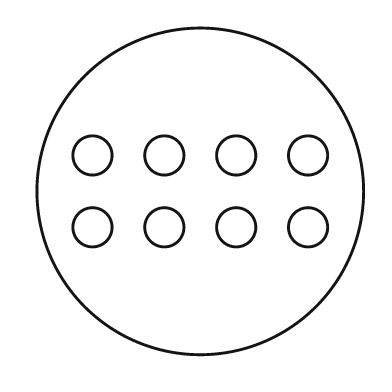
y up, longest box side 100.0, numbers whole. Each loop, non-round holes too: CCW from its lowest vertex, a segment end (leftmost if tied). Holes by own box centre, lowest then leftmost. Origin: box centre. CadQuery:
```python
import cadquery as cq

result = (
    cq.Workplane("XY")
    .moveTo(0.0, 0.0)
    .circle(50.0)
    .moveTo(-33.0, -11.0)
    .circle(6.0)
    .moveTo(-11.0, -11.0)
    .circle(6.0)
    .moveTo(11.0, -11.0)
    .circle(6.0)
    .moveTo(33.0, -11.0)
    .circle(6.0)
    .moveTo(-33.0, 11.0)
    .circle(6.0)
    .moveTo(-11.0, 11.0)
    .circle(6.0)
    .moveTo(11.0, 11.0)
    .circle(6.0)
    .moveTo(33.0, 11.0)
    .circle(6.0)
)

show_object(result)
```